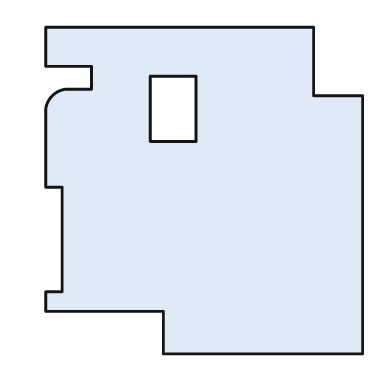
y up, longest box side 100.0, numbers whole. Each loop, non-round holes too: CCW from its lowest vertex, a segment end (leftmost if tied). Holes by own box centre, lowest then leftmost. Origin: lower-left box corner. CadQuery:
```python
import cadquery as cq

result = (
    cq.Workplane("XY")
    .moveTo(36.0, 0.0)
    .lineTo(97.0, 0.0)
    .lineTo(97.0, 79.0)
    .lineTo(82.0, 79.0)
    .lineTo(82.0, 100.0)
    .lineTo(0.0, 100.0)
    .lineTo(0.0, 88.0)
    .lineTo(14.0, 88.0)
    .lineTo(14.0, 81.0)
    .lineTo(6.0, 81.0)
    .threePointArc((2.0, 79.0), (0.0, 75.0))
    .lineTo(0.0, 51.0)
    .lineTo(5.0, 51.0)
    .lineTo(5.0, 19.0)
    .lineTo(0.0, 19.0)
    .lineTo(0.0, 13.0)
    .lineTo(36.0, 13.0)
    .close()
    .moveTo(32.0, 65.0)
    .lineTo(46.0, 65.0)
    .lineTo(46.0, 85.0)
    .lineTo(32.0, 85.0)
    .close()
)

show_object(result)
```